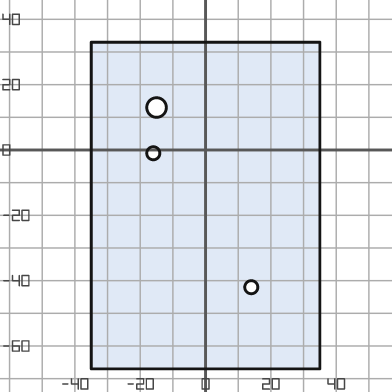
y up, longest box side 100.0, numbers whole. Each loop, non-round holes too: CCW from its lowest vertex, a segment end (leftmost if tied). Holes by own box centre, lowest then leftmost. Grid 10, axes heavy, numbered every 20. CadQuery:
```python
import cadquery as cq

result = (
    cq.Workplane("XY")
    .moveTo(-35.0, -67.0)
    .lineTo(35.0, -67.0)
    .lineTo(35.0, 33.0)
    .lineTo(-35.0, 33.0)
    .close()
    .moveTo(14.0, -42.0)
    .circle(2.0)
    .moveTo(-16.0, -1.0)
    .circle(2.0)
    .moveTo(-15.0, 13.0)
    .circle(3.0)
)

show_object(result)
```